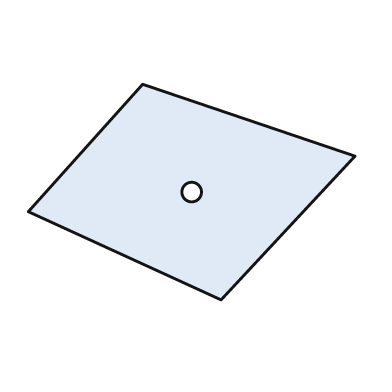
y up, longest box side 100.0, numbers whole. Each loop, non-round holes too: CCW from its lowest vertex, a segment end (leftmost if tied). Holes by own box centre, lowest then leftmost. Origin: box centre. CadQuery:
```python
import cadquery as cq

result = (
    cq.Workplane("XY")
    .moveTo(9.0, -33.0)
    .lineTo(50.0, 11.0)
    .lineTo(-15.0, 33.0)
    .lineTo(-50.0, -6.0)
    .close()
    .moveTo(0.0, 0.0)
    .circle(3.0)
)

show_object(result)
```